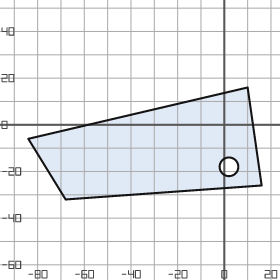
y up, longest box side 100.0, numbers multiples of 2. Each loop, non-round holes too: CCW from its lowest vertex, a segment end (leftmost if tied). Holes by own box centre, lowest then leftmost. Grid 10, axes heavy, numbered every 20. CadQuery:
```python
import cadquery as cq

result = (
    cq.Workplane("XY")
    .moveTo(-68.0, -32.0)
    .lineTo(16.0, -26.0)
    .lineTo(10.0, 16.0)
    .lineTo(-84.0, -6.0)
    .close()
    .moveTo(2.0, -18.0)
    .circle(4.0)
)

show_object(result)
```